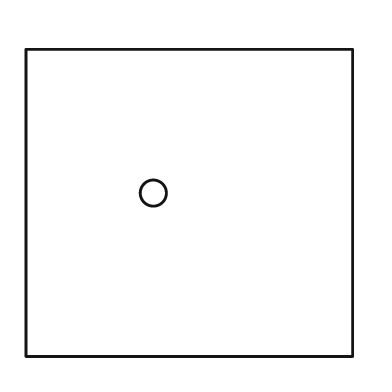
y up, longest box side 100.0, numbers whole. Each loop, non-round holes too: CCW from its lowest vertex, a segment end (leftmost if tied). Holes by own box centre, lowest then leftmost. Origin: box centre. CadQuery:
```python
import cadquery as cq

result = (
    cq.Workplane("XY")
    .moveTo(-50.0, -47.0)
    .lineTo(50.0, -47.0)
    .lineTo(50.0, 47.0)
    .lineTo(-50.0, 47.0)
    .close()
    .moveTo(-11.0, 3.0)
    .circle(4.0)
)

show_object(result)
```